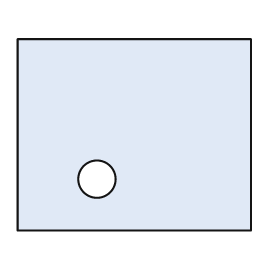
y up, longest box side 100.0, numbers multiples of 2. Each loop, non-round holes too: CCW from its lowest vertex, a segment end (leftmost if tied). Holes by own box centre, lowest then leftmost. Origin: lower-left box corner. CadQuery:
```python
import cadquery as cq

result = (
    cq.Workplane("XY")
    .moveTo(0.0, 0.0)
    .lineTo(100.0, 0.0)
    .lineTo(100.0, 82.0)
    .lineTo(0.0, 82.0)
    .close()
    .moveTo(34.0, 22.0)
    .circle(8.0)
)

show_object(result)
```